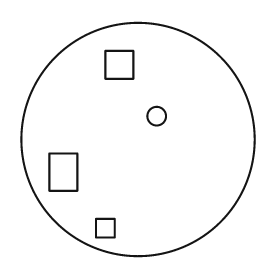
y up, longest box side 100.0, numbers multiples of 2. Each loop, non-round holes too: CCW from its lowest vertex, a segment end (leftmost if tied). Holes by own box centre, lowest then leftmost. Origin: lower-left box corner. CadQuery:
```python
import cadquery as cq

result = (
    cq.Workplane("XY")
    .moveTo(50.0, 50.0)
    .circle(50.0)
    .moveTo(32.0, 8.0)
    .lineTo(40.0, 8.0)
    .lineTo(40.0, 16.0)
    .lineTo(32.0, 16.0)
    .close()
    .moveTo(12.0, 28.0)
    .lineTo(24.0, 28.0)
    .lineTo(24.0, 44.0)
    .lineTo(12.0, 44.0)
    .close()
    .moveTo(58.0, 60.0)
    .circle(4.0)
    .moveTo(36.0, 76.0)
    .lineTo(48.0, 76.0)
    .lineTo(48.0, 88.0)
    .lineTo(36.0, 88.0)
    .close()
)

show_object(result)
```